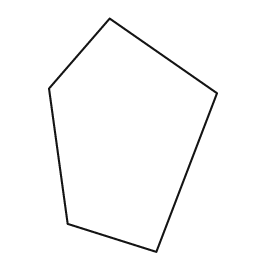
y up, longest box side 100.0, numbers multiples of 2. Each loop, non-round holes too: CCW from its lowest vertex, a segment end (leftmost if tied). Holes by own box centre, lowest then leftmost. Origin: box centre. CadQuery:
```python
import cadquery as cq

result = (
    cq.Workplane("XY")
    .moveTo(10.0, -50.0)
    .lineTo(36.0, 18.0)
    .lineTo(-10.0, 50.0)
    .lineTo(-36.0, 20.0)
    .lineTo(-28.0, -38.0)
    .close()
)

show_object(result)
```